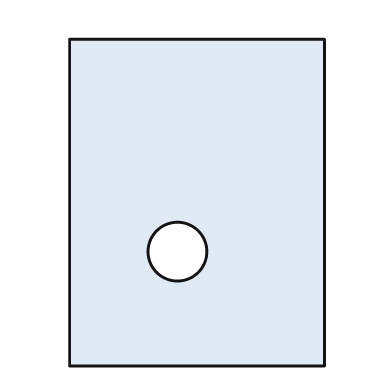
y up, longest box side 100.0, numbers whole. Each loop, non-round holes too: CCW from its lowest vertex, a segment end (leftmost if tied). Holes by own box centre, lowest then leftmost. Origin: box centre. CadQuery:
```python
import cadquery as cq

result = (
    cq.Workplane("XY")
    .moveTo(-39.0, -50.0)
    .lineTo(39.0, -50.0)
    .lineTo(39.0, 50.0)
    .lineTo(-39.0, 50.0)
    .close()
    .moveTo(-6.0, -15.0)
    .circle(9.0)
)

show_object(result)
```